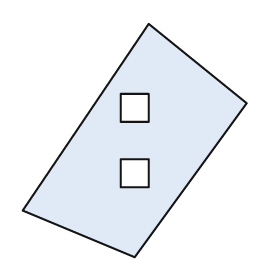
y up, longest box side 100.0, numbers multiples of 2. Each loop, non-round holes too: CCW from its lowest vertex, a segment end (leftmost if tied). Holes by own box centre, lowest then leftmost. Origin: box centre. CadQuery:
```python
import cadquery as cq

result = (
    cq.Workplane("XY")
    .moveTo(0.0, -50.0)
    .lineTo(48.0, 16.0)
    .lineTo(6.0, 50.0)
    .lineTo(-48.0, -30.0)
    .close()
    .moveTo(-6.0, -20.0)
    .lineTo(6.0, -20.0)
    .lineTo(6.0, -8.0)
    .lineTo(-6.0, -8.0)
    .close()
    .moveTo(-6.0, 8.0)
    .lineTo(6.0, 8.0)
    .lineTo(6.0, 20.0)
    .lineTo(-6.0, 20.0)
    .close()
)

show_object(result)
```